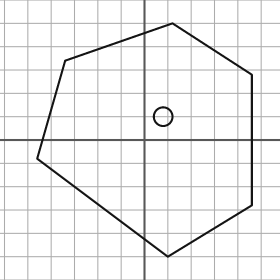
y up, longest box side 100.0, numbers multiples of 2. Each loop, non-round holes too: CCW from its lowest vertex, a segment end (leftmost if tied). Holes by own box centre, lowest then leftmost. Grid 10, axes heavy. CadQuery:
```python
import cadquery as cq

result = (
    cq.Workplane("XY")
    .moveTo(10.0, -50.0)
    .lineTo(46.0, -28.0)
    .lineTo(46.0, 28.0)
    .lineTo(12.0, 50.0)
    .lineTo(-34.0, 34.0)
    .lineTo(-46.0, -8.0)
    .close()
    .moveTo(8.0, 10.0)
    .circle(4.0)
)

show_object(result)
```